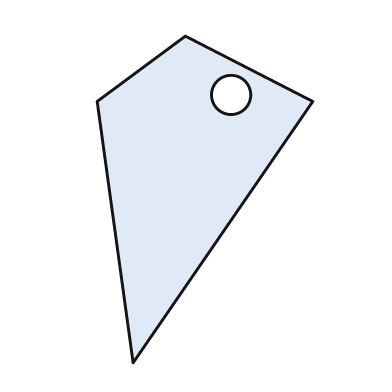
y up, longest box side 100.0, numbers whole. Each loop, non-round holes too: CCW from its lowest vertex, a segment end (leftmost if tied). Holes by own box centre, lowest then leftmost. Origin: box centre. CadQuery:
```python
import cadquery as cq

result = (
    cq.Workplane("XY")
    .moveTo(-22.0, -50.0)
    .lineTo(33.0, 30.0)
    .lineTo(-6.0, 50.0)
    .lineTo(-33.0, 30.0)
    .close()
    .moveTo(8.0, 32.0)
    .circle(6.0)
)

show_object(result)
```